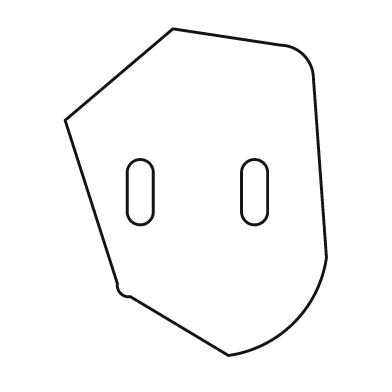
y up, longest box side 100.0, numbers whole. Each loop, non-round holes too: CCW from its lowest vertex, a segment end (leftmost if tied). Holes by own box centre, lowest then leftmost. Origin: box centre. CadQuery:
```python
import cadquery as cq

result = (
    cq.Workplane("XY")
    .moveTo(10.0, -50.0)
    .threePointArc((30.0, -40.0), (40.0, -20.0))
    .lineTo(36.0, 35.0)
    .threePointArc((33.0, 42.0), (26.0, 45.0))
    .lineTo(-7.0, 50.0)
    .lineTo(-40.0, 22.0)
    .lineTo(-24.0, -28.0)
    .threePointArc((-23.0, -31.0), (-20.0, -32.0))
    .close()
    .moveTo(-21.0, -6.0)
    .threePointArc((-17.0, -10.0), (-13.0, -6.0))
    .lineTo(-13.0, 6.0)
    .threePointArc((-17.0, 10.0), (-21.0, 6.0))
    .close()
    .moveTo(14.0, -6.0)
    .threePointArc((18.0, -10.0), (22.0, -6.0))
    .lineTo(22.0, 6.0)
    .threePointArc((18.0, 10.0), (14.0, 6.0))
    .close()
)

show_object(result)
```